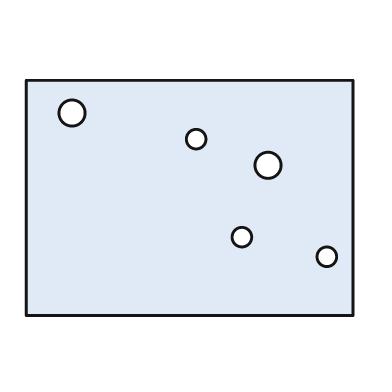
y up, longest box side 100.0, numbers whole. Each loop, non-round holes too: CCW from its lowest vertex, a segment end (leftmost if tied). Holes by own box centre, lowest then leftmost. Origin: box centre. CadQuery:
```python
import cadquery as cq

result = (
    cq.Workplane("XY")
    .moveTo(-50.0, -36.0)
    .lineTo(50.0, -36.0)
    .lineTo(50.0, 36.0)
    .lineTo(-50.0, 36.0)
    .close()
    .moveTo(42.0, -18.0)
    .circle(3.0)
    .moveTo(16.0, -12.0)
    .circle(3.0)
    .moveTo(24.0, 10.0)
    .circle(4.0)
    .moveTo(2.0, 18.0)
    .circle(3.0)
    .moveTo(-36.0, 26.0)
    .circle(4.0)
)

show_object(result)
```